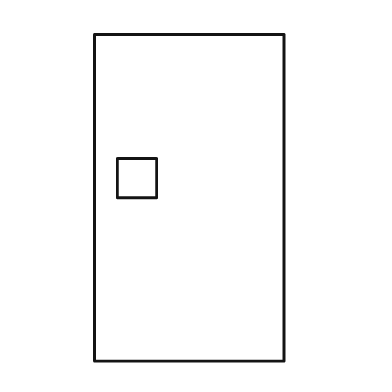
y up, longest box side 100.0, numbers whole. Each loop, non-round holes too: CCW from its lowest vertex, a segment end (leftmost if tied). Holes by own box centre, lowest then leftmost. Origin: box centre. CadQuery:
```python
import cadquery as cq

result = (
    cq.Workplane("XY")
    .moveTo(-29.0, -50.0)
    .lineTo(29.0, -50.0)
    .lineTo(29.0, 50.0)
    .lineTo(-29.0, 50.0)
    .close()
    .moveTo(-22.0, 0.0)
    .lineTo(-10.0, 0.0)
    .lineTo(-10.0, 12.0)
    .lineTo(-22.0, 12.0)
    .close()
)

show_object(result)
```